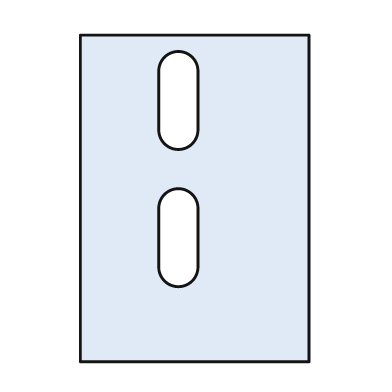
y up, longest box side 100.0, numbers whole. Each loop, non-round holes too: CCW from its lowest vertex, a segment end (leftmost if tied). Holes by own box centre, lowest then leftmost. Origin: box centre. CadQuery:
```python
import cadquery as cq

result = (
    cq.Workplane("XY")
    .moveTo(-35.0, -50.0)
    .lineTo(35.0, -50.0)
    .lineTo(35.0, 50.0)
    .lineTo(-35.0, 50.0)
    .close()
    .moveTo(-11.0, -21.0)
    .threePointArc((-5.0, -27.0), (1.0, -21.0))
    .lineTo(1.0, -3.0)
    .threePointArc((-5.0, 3.0), (-11.0, -3.0))
    .close()
    .moveTo(-11.0, 21.0)
    .threePointArc((-5.0, 15.0), (1.0, 21.0))
    .lineTo(1.0, 39.0)
    .threePointArc((-5.0, 45.0), (-11.0, 39.0))
    .close()
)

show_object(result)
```